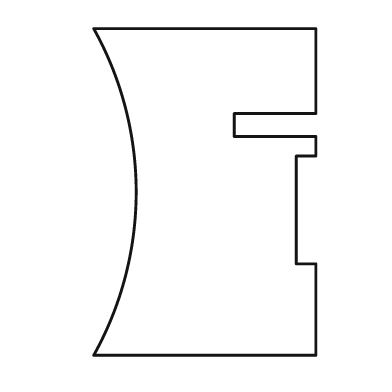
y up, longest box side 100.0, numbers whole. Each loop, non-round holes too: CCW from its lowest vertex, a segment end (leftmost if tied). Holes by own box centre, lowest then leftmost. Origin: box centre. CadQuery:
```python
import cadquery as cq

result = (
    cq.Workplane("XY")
    .moveTo(-34.0, -50.0)
    .lineTo(34.0, -50.0)
    .lineTo(34.0, -22.0)
    .lineTo(28.0, -22.0)
    .lineTo(28.0, 11.0)
    .lineTo(34.0, 11.0)
    .lineTo(34.0, 17.0)
    .lineTo(9.0, 17.0)
    .lineTo(9.0, 24.0)
    .lineTo(34.0, 24.0)
    .lineTo(34.0, 50.0)
    .lineTo(-34.0, 50.0)
    .threePointArc((-21.0, 0.0), (-34.0, -50.0))
    .close()
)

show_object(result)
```